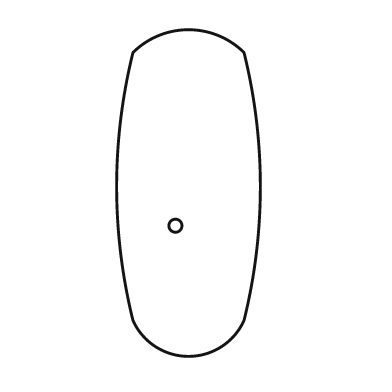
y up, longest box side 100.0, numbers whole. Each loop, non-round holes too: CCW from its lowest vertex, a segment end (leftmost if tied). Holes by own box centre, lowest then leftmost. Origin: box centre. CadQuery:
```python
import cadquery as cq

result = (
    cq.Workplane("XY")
    .moveTo(-17.0, -39.0)
    .threePointArc((0.0, -50.0), (17.0, -39.0))
    .threePointArc((22.0, 2.0), (17.0, 43.0))
    .threePointArc((0.0, 50.0), (-17.0, 43.0))
    .threePointArc((-22.0, 2.0), (-17.0, -39.0))
    .close()
    .moveTo(-4.0, -10.0)
    .circle(2.0)
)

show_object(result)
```